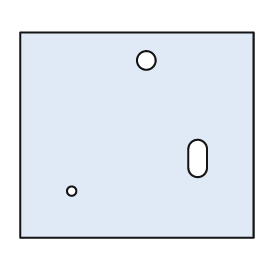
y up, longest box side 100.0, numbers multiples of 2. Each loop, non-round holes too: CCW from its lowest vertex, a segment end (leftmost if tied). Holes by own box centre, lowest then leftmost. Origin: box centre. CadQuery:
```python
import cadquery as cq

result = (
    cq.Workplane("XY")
    .moveTo(-50.0, -44.0)
    .lineTo(50.0, -44.0)
    .lineTo(50.0, 44.0)
    .lineTo(-50.0, 44.0)
    .close()
    .moveTo(-28.0, -24.0)
    .circle(2.0)
    .moveTo(22.0, -14.0)
    .threePointArc((26.0, -18.0), (30.0, -14.0))
    .lineTo(30.0, -6.0)
    .threePointArc((26.0, -2.0), (22.0, -6.0))
    .close()
    .moveTo(4.0, 32.0)
    .circle(4.0)
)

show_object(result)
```